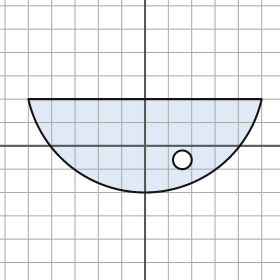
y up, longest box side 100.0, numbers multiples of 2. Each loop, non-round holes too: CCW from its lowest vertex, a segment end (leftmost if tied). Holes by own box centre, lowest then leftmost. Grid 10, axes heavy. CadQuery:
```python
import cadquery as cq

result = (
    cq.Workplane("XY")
    .moveTo(-50.0, 20.0)
    .threePointArc((0.0, -20.0), (50.0, 20.0))
    .close()
    .moveTo(16.0, -6.0)
    .circle(4.0)
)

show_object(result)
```